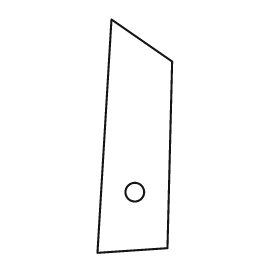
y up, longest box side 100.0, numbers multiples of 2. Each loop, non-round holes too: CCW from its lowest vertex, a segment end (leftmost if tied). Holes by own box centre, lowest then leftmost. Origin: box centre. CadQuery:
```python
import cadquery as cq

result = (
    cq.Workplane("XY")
    .moveTo(-16.0, -50.0)
    .lineTo(14.0, -48.0)
    .lineTo(16.0, 32.0)
    .lineTo(-10.0, 50.0)
    .close()
    .moveTo(0.0, -24.0)
    .circle(4.0)
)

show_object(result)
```